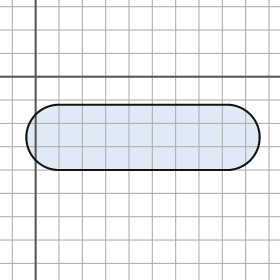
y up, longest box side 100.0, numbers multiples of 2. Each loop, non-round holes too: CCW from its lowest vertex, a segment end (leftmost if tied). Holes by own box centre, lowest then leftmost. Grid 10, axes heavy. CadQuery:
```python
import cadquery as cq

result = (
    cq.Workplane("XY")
    .moveTo(10.0, -40.0)
    .lineTo(82.0, -40.0)
    .threePointArc((96.0, -26.0), (82.0, -12.0))
    .lineTo(10.0, -12.0)
    .threePointArc((-4.0, -26.0), (10.0, -40.0))
    .close()
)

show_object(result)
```